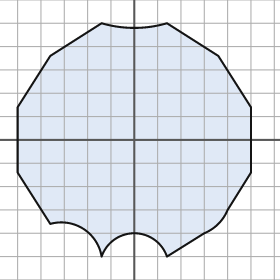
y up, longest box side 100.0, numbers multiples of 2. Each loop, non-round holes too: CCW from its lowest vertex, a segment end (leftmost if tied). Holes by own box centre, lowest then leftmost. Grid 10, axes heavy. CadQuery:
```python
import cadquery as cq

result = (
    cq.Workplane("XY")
    .moveTo(-14.0, -50.0)
    .threePointArc((0.0, -40.0), (14.0, -50.0))
    .lineTo(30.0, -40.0)
    .threePointArc((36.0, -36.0), (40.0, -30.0))
    .lineTo(50.0, -14.0)
    .lineTo(50.0, 14.0)
    .lineTo(36.0, 36.0)
    .lineTo(14.0, 50.0)
    .threePointArc((0.0, 48.0), (-14.0, 50.0))
    .lineTo(-36.0, 36.0)
    .lineTo(-50.0, 14.0)
    .lineTo(-50.0, -14.0)
    .lineTo(-36.0, -36.0)
    .threePointArc((-22.0, -38.0), (-14.0, -50.0))
    .close()
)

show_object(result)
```